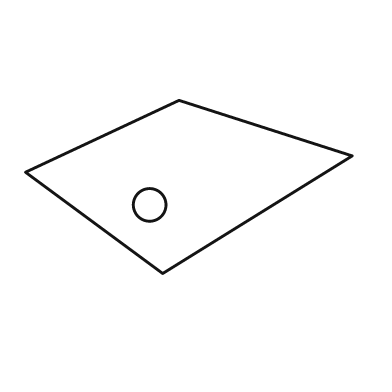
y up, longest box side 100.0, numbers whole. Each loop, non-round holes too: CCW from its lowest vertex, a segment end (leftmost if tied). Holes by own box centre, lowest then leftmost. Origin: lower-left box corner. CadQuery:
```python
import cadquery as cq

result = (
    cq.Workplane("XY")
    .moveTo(42.0, 0.0)
    .lineTo(100.0, 36.0)
    .lineTo(47.0, 53.0)
    .lineTo(0.0, 31.0)
    .close()
    .moveTo(38.0, 21.0)
    .circle(5.0)
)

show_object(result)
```